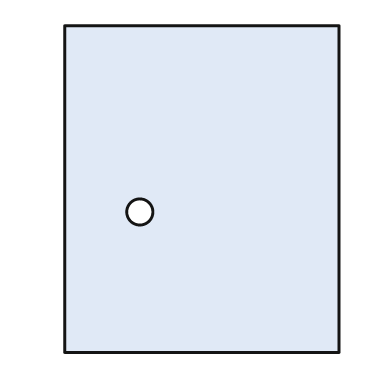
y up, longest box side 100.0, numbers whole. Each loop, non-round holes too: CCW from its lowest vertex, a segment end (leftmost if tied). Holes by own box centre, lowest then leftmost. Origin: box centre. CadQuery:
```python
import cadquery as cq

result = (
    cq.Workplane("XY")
    .moveTo(-42.0, -50.0)
    .lineTo(42.0, -50.0)
    .lineTo(42.0, 50.0)
    .lineTo(-42.0, 50.0)
    .close()
    .moveTo(-19.0, -7.0)
    .circle(4.0)
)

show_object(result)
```